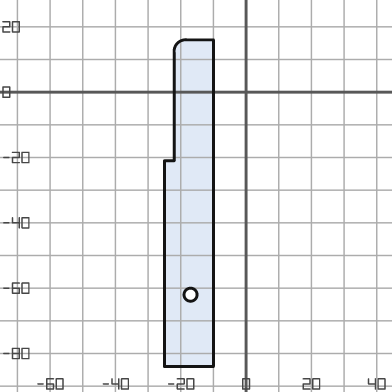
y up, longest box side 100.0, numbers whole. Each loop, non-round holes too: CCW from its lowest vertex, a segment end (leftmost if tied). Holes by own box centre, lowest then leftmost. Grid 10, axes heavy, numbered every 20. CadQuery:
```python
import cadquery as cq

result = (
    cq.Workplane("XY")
    .moveTo(-25.0, -84.0)
    .lineTo(-10.0, -84.0)
    .lineTo(-10.0, 16.0)
    .lineTo(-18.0, 16.0)
    .threePointArc((-21.0, 15.0), (-22.0, 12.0))
    .lineTo(-22.0, -21.0)
    .lineTo(-25.0, -21.0)
    .close()
    .moveTo(-17.0, -62.0)
    .circle(2.0)
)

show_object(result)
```